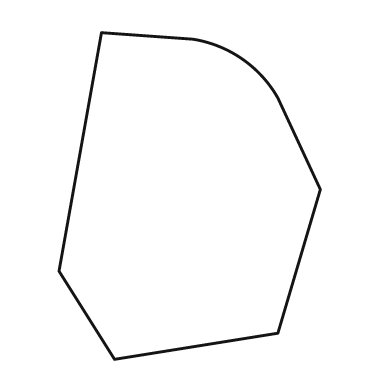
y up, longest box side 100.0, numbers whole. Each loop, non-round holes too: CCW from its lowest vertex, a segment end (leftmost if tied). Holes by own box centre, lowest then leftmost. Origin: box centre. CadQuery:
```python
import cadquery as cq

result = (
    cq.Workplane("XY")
    .moveTo(-23.0, -50.0)
    .lineTo(27.0, -42.0)
    .lineTo(40.0, 2.0)
    .lineTo(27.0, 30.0)
    .threePointArc((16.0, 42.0), (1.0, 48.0))
    .lineTo(-27.0, 50.0)
    .lineTo(-40.0, -23.0)
    .close()
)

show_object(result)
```